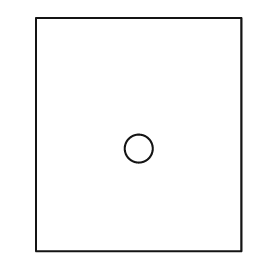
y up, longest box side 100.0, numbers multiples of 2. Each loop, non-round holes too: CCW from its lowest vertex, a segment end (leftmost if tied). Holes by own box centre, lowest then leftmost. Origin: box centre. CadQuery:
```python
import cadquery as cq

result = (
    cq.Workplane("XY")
    .moveTo(-44.0, -50.0)
    .lineTo(44.0, -50.0)
    .lineTo(44.0, 50.0)
    .lineTo(-44.0, 50.0)
    .close()
    .moveTo(0.0, -6.0)
    .circle(6.0)
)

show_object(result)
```